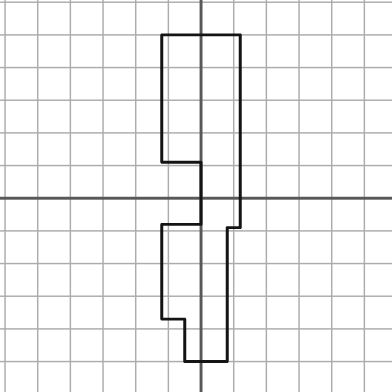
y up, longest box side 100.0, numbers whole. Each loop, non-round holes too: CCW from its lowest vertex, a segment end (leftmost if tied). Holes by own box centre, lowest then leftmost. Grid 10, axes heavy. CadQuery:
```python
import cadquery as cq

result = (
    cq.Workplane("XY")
    .moveTo(-5.0, -50.0)
    .lineTo(8.0, -50.0)
    .lineTo(8.0, -9.0)
    .lineTo(12.0, -9.0)
    .lineTo(12.0, 50.0)
    .lineTo(-12.0, 50.0)
    .lineTo(-12.0, 11.0)
    .lineTo(0.0, 11.0)
    .lineTo(0.0, -8.0)
    .lineTo(-12.0, -8.0)
    .lineTo(-12.0, -37.0)
    .lineTo(-5.0, -37.0)
    .close()
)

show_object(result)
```